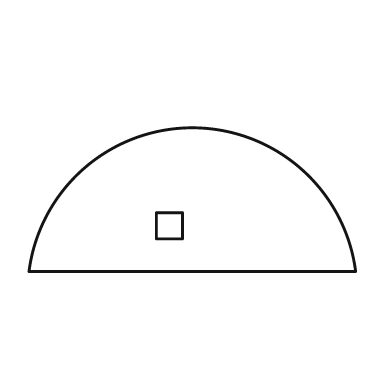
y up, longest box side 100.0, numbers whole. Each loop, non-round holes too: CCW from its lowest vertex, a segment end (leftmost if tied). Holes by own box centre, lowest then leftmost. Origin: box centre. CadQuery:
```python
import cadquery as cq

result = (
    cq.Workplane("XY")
    .moveTo(-50.0, -22.0)
    .lineTo(50.0, -22.0)
    .threePointArc((0.0, 22.0), (-50.0, -22.0))
    .close()
    .moveTo(-11.0, -12.0)
    .lineTo(-3.0, -12.0)
    .lineTo(-3.0, -4.0)
    .lineTo(-11.0, -4.0)
    .close()
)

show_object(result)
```